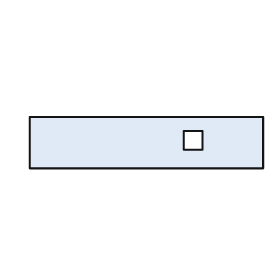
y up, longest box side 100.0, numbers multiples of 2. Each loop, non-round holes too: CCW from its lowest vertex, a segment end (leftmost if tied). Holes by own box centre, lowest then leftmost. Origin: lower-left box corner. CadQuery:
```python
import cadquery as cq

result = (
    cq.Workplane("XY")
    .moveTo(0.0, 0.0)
    .lineTo(100.0, 0.0)
    .lineTo(100.0, 22.0)
    .lineTo(0.0, 22.0)
    .close()
    .moveTo(66.0, 8.0)
    .lineTo(74.0, 8.0)
    .lineTo(74.0, 16.0)
    .lineTo(66.0, 16.0)
    .close()
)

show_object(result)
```